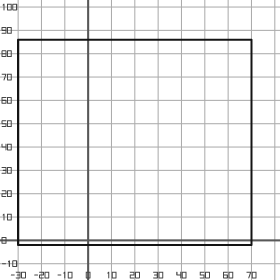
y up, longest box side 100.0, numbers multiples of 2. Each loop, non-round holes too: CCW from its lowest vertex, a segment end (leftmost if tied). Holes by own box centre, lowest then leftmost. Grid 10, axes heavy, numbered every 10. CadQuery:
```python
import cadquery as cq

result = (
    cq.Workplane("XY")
    .moveTo(-30.0, -2.0)
    .lineTo(70.0, -2.0)
    .lineTo(70.0, 86.0)
    .lineTo(-30.0, 86.0)
    .close()
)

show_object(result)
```